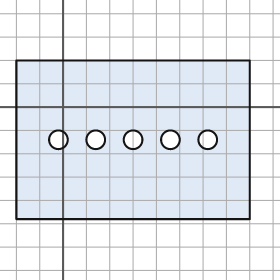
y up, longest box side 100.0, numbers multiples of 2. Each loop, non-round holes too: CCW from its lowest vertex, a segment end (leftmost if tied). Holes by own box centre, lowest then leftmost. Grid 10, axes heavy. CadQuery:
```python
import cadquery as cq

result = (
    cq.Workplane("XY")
    .moveTo(-20.0, -48.0)
    .lineTo(80.0, -48.0)
    .lineTo(80.0, 20.0)
    .lineTo(-20.0, 20.0)
    .close()
    .moveTo(-2.0, -14.0)
    .circle(4.0)
    .moveTo(14.0, -14.0)
    .circle(4.0)
    .moveTo(30.0, -14.0)
    .circle(4.0)
    .moveTo(46.0, -14.0)
    .circle(4.0)
    .moveTo(62.0, -14.0)
    .circle(4.0)
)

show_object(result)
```